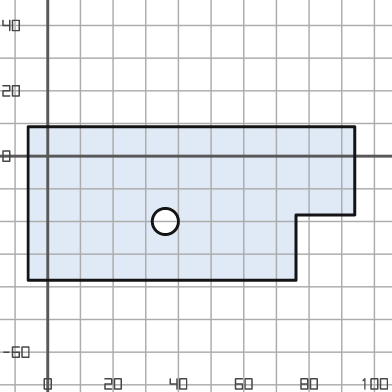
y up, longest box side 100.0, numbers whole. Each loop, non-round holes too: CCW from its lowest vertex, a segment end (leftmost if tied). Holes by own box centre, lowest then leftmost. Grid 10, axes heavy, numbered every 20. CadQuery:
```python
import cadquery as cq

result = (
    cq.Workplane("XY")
    .moveTo(-6.0, -38.0)
    .lineTo(76.0, -38.0)
    .lineTo(76.0, -18.0)
    .lineTo(94.0, -18.0)
    .lineTo(94.0, 9.0)
    .lineTo(-6.0, 9.0)
    .close()
    .moveTo(36.0, -20.0)
    .circle(4.0)
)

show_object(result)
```